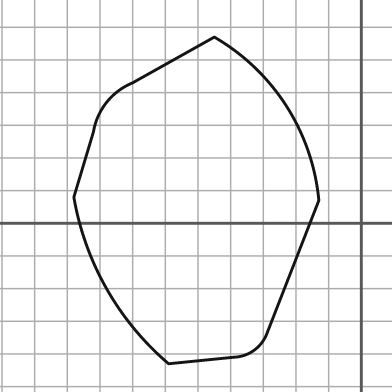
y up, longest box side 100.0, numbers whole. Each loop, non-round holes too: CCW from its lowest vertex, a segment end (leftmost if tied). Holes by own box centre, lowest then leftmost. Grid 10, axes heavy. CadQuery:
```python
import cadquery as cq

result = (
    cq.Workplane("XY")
    .moveTo(-59.0, -43.0)
    .lineTo(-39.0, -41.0)
    .threePointArc((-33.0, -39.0), (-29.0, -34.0))
    .lineTo(-13.0, 7.0)
    .threePointArc((-23.0, 36.0), (-45.0, 57.0))
    .lineTo(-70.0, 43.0)
    .threePointArc((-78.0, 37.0), (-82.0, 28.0))
    .lineTo(-88.0, 8.0)
    .threePointArc((-78.0, -20.0), (-59.0, -43.0))
    .close()
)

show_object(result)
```